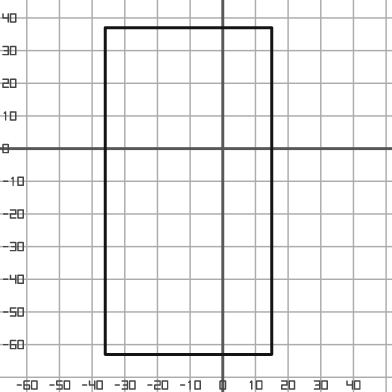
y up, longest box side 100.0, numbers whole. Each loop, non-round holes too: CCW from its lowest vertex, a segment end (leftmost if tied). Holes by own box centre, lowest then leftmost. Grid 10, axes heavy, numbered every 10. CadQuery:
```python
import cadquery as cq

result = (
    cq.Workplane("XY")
    .moveTo(-36.0, -63.0)
    .lineTo(15.0, -63.0)
    .lineTo(15.0, 37.0)
    .lineTo(-36.0, 37.0)
    .close()
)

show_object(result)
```